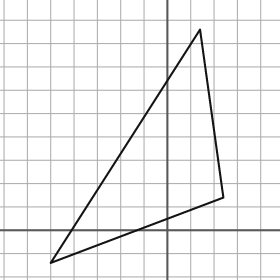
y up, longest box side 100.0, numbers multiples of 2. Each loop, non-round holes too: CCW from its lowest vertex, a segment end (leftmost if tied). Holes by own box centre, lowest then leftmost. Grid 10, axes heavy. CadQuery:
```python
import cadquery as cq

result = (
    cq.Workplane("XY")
    .moveTo(-50.0, -14.0)
    .lineTo(24.0, 14.0)
    .lineTo(14.0, 86.0)
    .close()
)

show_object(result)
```